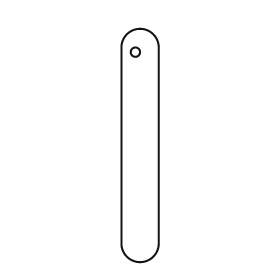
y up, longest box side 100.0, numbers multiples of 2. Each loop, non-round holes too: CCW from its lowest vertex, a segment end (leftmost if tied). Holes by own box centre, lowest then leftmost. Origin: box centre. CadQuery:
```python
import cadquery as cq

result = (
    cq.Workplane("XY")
    .moveTo(-8.0, -42.0)
    .threePointArc((0.0, -50.0), (8.0, -42.0))
    .lineTo(8.0, 42.0)
    .threePointArc((0.0, 50.0), (-8.0, 42.0))
    .close()
    .moveTo(-2.0, 40.0)
    .circle(2.0)
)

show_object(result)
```